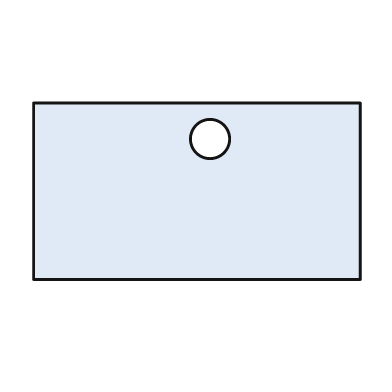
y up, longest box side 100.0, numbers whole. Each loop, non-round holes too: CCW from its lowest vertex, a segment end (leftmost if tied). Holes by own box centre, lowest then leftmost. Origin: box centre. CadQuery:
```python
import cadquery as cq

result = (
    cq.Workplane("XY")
    .moveTo(-50.0, -27.0)
    .lineTo(50.0, -27.0)
    .lineTo(50.0, 27.0)
    .lineTo(-50.0, 27.0)
    .close()
    .moveTo(4.0, 16.0)
    .circle(6.0)
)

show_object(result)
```